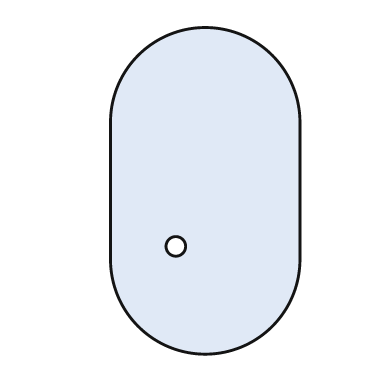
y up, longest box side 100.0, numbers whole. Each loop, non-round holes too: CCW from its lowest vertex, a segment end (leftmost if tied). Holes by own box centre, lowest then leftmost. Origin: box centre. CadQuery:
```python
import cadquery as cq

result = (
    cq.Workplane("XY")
    .moveTo(-29.0, -21.0)
    .threePointArc((0.0, -50.0), (29.0, -21.0))
    .lineTo(29.0, 21.0)
    .threePointArc((0.0, 50.0), (-29.0, 21.0))
    .close()
    .moveTo(-9.0, -17.0)
    .circle(3.0)
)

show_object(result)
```